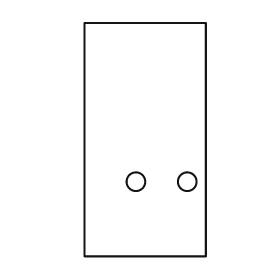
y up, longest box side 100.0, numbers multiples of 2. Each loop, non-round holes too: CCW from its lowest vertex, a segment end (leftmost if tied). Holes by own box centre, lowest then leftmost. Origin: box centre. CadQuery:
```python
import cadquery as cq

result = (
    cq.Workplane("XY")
    .moveTo(-26.0, -50.0)
    .lineTo(26.0, -50.0)
    .lineTo(26.0, 50.0)
    .lineTo(-26.0, 50.0)
    .close()
    .moveTo(-4.0, -18.0)
    .circle(4.0)
    .moveTo(18.0, -18.0)
    .circle(4.0)
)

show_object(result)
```